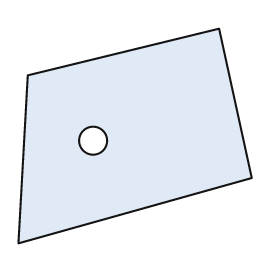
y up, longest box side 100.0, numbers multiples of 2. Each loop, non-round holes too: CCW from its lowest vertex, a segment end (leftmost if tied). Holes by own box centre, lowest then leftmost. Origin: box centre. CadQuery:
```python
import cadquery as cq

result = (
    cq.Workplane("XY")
    .moveTo(-50.0, -46.0)
    .lineTo(50.0, -18.0)
    .lineTo(36.0, 46.0)
    .lineTo(-46.0, 26.0)
    .close()
    .moveTo(-18.0, -2.0)
    .circle(6.0)
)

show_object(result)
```